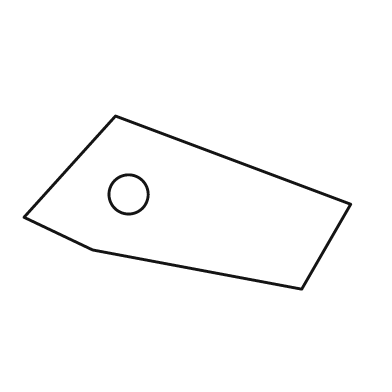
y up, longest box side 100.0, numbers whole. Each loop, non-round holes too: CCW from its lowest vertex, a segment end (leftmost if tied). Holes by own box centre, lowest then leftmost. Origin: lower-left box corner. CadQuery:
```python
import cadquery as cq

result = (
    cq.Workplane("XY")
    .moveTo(85.0, 0.0)
    .lineTo(100.0, 26.0)
    .lineTo(28.0, 53.0)
    .lineTo(0.0, 22.0)
    .lineTo(21.0, 12.0)
    .close()
    .moveTo(32.0, 29.0)
    .circle(6.0)
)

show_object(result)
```